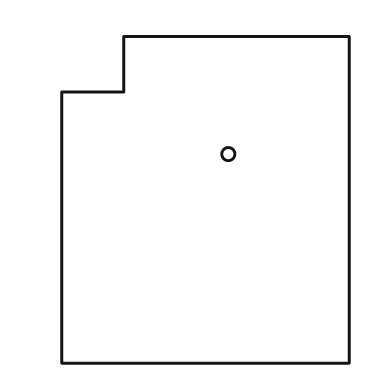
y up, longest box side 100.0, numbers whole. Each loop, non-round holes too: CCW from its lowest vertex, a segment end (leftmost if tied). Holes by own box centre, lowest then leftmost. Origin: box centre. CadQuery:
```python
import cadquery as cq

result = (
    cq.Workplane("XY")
    .moveTo(-44.0, -50.0)
    .lineTo(44.0, -50.0)
    .lineTo(44.0, 50.0)
    .lineTo(-25.0, 50.0)
    .lineTo(-25.0, 33.0)
    .lineTo(-44.0, 33.0)
    .close()
    .moveTo(7.0, 14.0)
    .circle(2.0)
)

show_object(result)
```